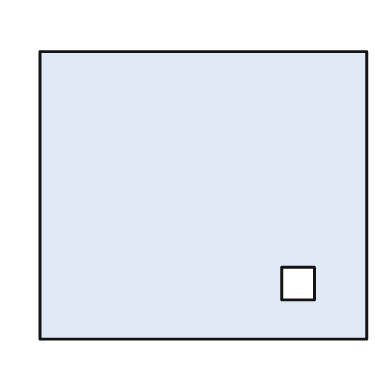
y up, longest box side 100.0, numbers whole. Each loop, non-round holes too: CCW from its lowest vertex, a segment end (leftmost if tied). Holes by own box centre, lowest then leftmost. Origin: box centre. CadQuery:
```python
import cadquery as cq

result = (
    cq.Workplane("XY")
    .moveTo(-50.0, -44.0)
    .lineTo(50.0, -44.0)
    .lineTo(50.0, 44.0)
    .lineTo(-50.0, 44.0)
    .close()
    .moveTo(24.0, -32.0)
    .lineTo(34.0, -32.0)
    .lineTo(34.0, -22.0)
    .lineTo(24.0, -22.0)
    .close()
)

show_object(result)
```